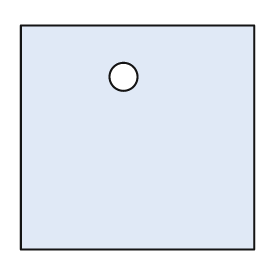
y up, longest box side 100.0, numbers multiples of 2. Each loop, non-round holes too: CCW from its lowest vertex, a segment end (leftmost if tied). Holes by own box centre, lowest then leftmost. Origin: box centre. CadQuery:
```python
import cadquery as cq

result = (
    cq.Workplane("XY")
    .moveTo(-50.0, -48.0)
    .lineTo(50.0, -48.0)
    .lineTo(50.0, 48.0)
    .lineTo(-50.0, 48.0)
    .close()
    .moveTo(-6.0, 26.0)
    .circle(6.0)
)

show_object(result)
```